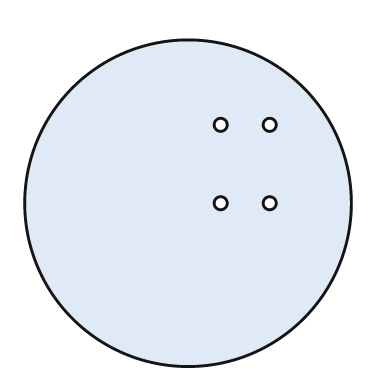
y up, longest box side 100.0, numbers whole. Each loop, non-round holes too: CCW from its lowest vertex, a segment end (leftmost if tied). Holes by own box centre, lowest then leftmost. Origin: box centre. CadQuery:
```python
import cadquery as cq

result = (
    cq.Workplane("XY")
    .moveTo(0.0, 0.0)
    .circle(50.0)
    .moveTo(10.0, 0.0)
    .circle(2.0)
    .moveTo(25.0, 0.0)
    .circle(2.0)
    .moveTo(10.0, 24.0)
    .circle(2.0)
    .moveTo(25.0, 24.0)
    .circle(2.0)
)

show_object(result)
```